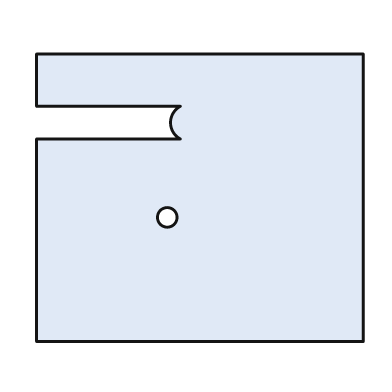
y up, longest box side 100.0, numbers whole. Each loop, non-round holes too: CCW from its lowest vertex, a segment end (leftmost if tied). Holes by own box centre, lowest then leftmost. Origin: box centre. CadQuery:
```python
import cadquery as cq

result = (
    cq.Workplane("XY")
    .moveTo(-50.0, -44.0)
    .lineTo(50.0, -44.0)
    .lineTo(50.0, 44.0)
    .lineTo(-50.0, 44.0)
    .lineTo(-50.0, 28.0)
    .lineTo(-6.0, 28.0)
    .threePointArc((-9.0, 23.0), (-6.0, 18.0))
    .lineTo(-50.0, 18.0)
    .close()
    .moveTo(-10.0, -6.0)
    .circle(3.0)
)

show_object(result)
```